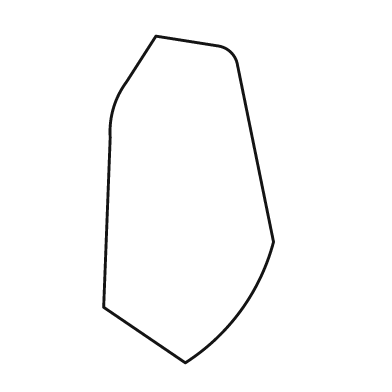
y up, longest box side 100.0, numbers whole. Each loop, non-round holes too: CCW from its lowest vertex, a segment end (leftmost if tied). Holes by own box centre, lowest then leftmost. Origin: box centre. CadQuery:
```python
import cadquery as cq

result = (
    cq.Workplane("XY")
    .moveTo(-1.0, -50.0)
    .threePointArc((16.0, -34.0), (26.0, -13.0))
    .lineTo(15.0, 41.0)
    .threePointArc((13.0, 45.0), (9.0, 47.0))
    .lineTo(-10.0, 50.0)
    .lineTo(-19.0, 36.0)
    .threePointArc((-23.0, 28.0), (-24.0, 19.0))
    .lineTo(-26.0, -33.0)
    .close()
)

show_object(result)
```